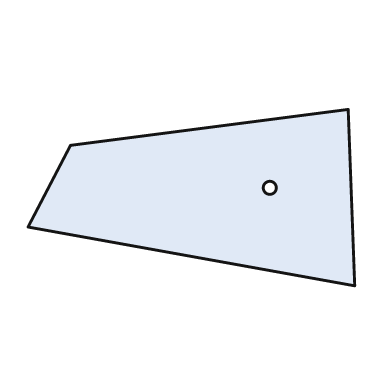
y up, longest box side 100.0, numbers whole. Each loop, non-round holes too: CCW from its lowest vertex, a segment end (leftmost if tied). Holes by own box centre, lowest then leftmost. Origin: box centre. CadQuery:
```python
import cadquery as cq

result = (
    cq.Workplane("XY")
    .moveTo(50.0, -27.0)
    .lineTo(48.0, 27.0)
    .lineTo(-37.0, 16.0)
    .lineTo(-50.0, -9.0)
    .close()
    .moveTo(24.0, 3.0)
    .circle(2.0)
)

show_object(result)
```